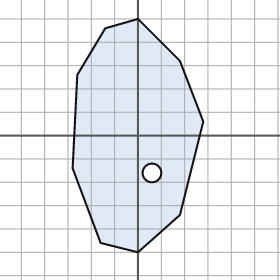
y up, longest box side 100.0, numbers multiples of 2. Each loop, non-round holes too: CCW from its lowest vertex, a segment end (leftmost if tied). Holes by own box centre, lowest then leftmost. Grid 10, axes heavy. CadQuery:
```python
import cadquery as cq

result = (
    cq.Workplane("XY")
    .moveTo(0.0, -50.0)
    .lineTo(18.0, -34.0)
    .lineTo(28.0, 6.0)
    .lineTo(18.0, 32.0)
    .lineTo(0.0, 50.0)
    .lineTo(-14.0, 46.0)
    .lineTo(-26.0, 26.0)
    .lineTo(-28.0, -14.0)
    .lineTo(-16.0, -46.0)
    .close()
    .moveTo(6.0, -16.0)
    .circle(4.0)
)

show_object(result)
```